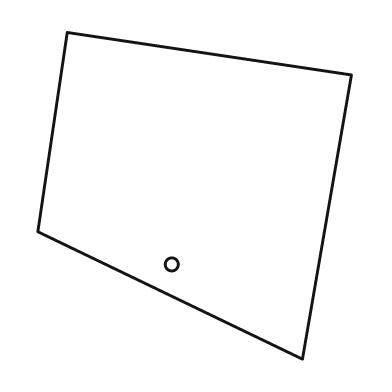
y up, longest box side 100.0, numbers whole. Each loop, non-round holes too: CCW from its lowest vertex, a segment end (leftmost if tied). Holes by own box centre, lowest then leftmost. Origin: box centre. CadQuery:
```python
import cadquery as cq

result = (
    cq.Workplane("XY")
    .moveTo(33.0, -50.0)
    .lineTo(48.0, 37.0)
    .lineTo(-39.0, 50.0)
    .lineTo(-48.0, -11.0)
    .close()
    .moveTo(-7.0, -21.0)
    .circle(2.0)
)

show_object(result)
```